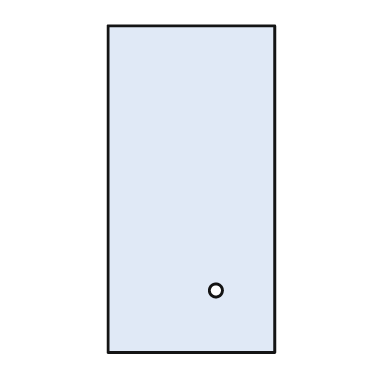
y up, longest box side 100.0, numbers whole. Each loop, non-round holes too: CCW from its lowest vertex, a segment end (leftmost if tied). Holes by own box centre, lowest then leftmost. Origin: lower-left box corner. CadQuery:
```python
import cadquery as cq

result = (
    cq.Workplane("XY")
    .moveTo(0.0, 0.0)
    .lineTo(51.0, 0.0)
    .lineTo(51.0, 100.0)
    .lineTo(0.0, 100.0)
    .close()
    .moveTo(33.0, 19.0)
    .circle(2.0)
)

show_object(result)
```